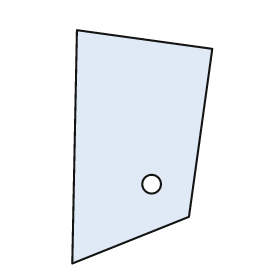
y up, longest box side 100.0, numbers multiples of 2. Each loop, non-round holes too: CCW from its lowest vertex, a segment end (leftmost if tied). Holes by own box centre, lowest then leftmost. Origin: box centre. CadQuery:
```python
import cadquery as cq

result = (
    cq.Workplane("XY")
    .moveTo(-30.0, -50.0)
    .lineTo(20.0, -30.0)
    .lineTo(30.0, 42.0)
    .lineTo(-28.0, 50.0)
    .close()
    .moveTo(4.0, -16.0)
    .circle(4.0)
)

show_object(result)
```